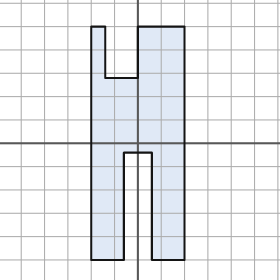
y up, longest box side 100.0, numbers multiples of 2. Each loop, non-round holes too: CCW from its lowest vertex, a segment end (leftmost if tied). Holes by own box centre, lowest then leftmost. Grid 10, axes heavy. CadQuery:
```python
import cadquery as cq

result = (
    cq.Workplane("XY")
    .moveTo(-20.0, -50.0)
    .lineTo(-6.0, -50.0)
    .lineTo(-6.0, -4.0)
    .lineTo(6.0, -4.0)
    .lineTo(6.0, -50.0)
    .lineTo(20.0, -50.0)
    .lineTo(20.0, 50.0)
    .lineTo(0.0, 50.0)
    .lineTo(0.0, 28.0)
    .lineTo(-14.0, 28.0)
    .lineTo(-14.0, 50.0)
    .lineTo(-20.0, 50.0)
    .close()
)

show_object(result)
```